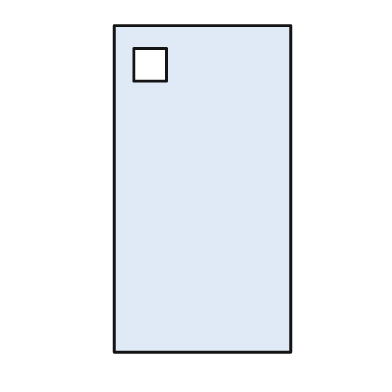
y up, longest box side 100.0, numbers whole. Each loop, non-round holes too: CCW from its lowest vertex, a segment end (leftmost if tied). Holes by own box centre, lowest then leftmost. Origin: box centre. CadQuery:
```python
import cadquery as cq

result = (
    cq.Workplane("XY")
    .moveTo(-27.0, -50.0)
    .lineTo(27.0, -50.0)
    .lineTo(27.0, 50.0)
    .lineTo(-27.0, 50.0)
    .close()
    .moveTo(-21.0, 33.0)
    .lineTo(-11.0, 33.0)
    .lineTo(-11.0, 43.0)
    .lineTo(-21.0, 43.0)
    .close()
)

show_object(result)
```